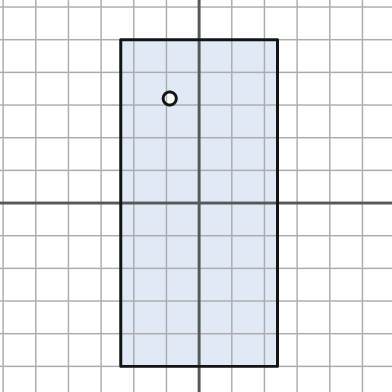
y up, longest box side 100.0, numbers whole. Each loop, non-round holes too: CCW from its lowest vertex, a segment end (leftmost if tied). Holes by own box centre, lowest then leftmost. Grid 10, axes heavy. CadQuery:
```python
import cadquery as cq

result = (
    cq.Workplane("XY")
    .moveTo(-24.0, -50.0)
    .lineTo(24.0, -50.0)
    .lineTo(24.0, 50.0)
    .lineTo(-24.0, 50.0)
    .close()
    .moveTo(-9.0, 32.0)
    .circle(2.0)
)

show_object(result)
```